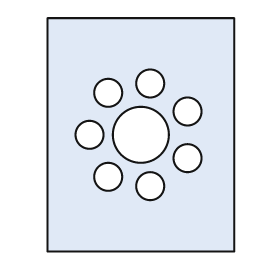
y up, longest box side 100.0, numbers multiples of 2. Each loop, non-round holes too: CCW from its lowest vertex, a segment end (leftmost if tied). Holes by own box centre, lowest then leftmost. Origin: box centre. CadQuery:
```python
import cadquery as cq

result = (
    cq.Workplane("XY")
    .moveTo(-40.0, -50.0)
    .lineTo(40.0, -50.0)
    .lineTo(40.0, 50.0)
    .lineTo(-40.0, 50.0)
    .close()
    .moveTo(4.0, -22.0)
    .circle(6.0)
    .moveTo(-14.0, -18.0)
    .circle(6.0)
    .moveTo(20.0, -10.0)
    .circle(6.0)
    .moveTo(-22.0, 0.0)
    .circle(6.0)
    .moveTo(0.0, 0.0)
    .circle(12.0)
    .moveTo(20.0, 10.0)
    .circle(6.0)
    .moveTo(-14.0, 18.0)
    .circle(6.0)
    .moveTo(4.0, 22.0)
    .circle(6.0)
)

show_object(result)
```